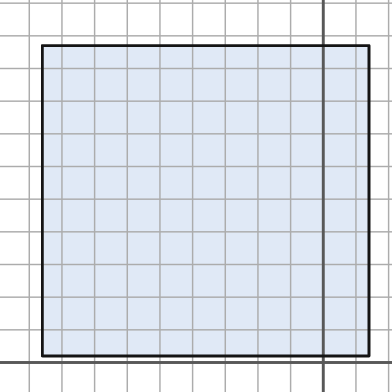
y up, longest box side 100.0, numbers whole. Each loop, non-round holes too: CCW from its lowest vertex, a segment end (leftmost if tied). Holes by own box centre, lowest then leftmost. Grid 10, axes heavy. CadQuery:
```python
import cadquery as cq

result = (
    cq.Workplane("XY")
    .moveTo(-86.0, 2.0)
    .lineTo(14.0, 2.0)
    .lineTo(14.0, 97.0)
    .lineTo(-86.0, 97.0)
    .close()
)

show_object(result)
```